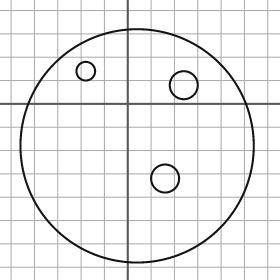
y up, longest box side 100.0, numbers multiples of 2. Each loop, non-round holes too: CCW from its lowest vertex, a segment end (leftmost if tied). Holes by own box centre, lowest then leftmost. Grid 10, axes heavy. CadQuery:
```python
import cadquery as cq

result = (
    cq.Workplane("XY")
    .moveTo(4.0, -18.0)
    .circle(50.0)
    .moveTo(16.0, -32.0)
    .circle(6.0)
    .moveTo(24.0, 8.0)
    .circle(6.0)
    .moveTo(-18.0, 14.0)
    .circle(4.0)
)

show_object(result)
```